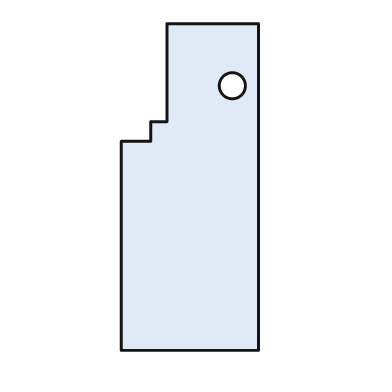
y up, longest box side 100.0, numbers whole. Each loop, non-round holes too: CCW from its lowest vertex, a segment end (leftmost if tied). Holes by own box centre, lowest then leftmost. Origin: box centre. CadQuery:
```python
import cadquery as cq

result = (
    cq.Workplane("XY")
    .moveTo(-21.0, -50.0)
    .lineTo(21.0, -50.0)
    .lineTo(21.0, 50.0)
    .lineTo(-7.0, 50.0)
    .lineTo(-7.0, 20.0)
    .lineTo(-12.0, 20.0)
    .lineTo(-12.0, 14.0)
    .lineTo(-21.0, 14.0)
    .close()
    .moveTo(13.0, 31.0)
    .circle(4.0)
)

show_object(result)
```